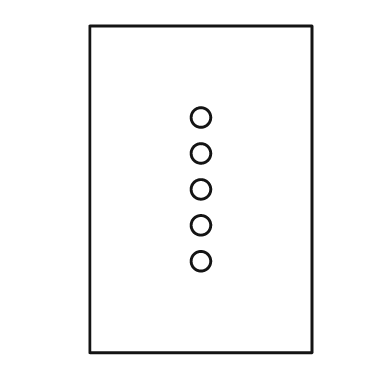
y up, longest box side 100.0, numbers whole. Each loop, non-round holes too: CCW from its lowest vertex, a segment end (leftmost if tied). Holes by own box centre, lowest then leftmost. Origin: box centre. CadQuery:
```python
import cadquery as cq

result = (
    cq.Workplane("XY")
    .moveTo(-34.0, -50.0)
    .lineTo(34.0, -50.0)
    .lineTo(34.0, 50.0)
    .lineTo(-34.0, 50.0)
    .close()
    .moveTo(0.0, -22.0)
    .circle(3.0)
    .moveTo(0.0, -11.0)
    .circle(3.0)
    .moveTo(0.0, 0.0)
    .circle(3.0)
    .moveTo(0.0, 11.0)
    .circle(3.0)
    .moveTo(0.0, 22.0)
    .circle(3.0)
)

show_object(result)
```